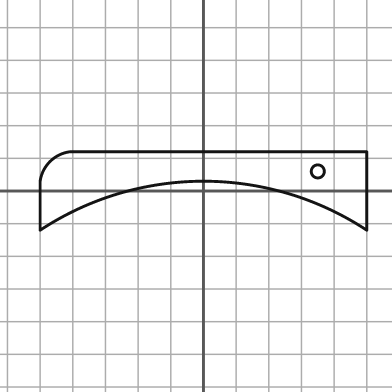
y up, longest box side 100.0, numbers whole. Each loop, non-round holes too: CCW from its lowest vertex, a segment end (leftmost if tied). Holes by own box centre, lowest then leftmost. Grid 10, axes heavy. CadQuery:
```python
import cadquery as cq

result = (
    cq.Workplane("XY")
    .moveTo(-50.0, -12.0)
    .threePointArc((0.0, 3.0), (50.0, -12.0))
    .lineTo(50.0, 12.0)
    .lineTo(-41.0, 12.0)
    .threePointArc((-47.0, 9.0), (-50.0, 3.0))
    .close()
    .moveTo(35.0, 6.0)
    .circle(2.0)
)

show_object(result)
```